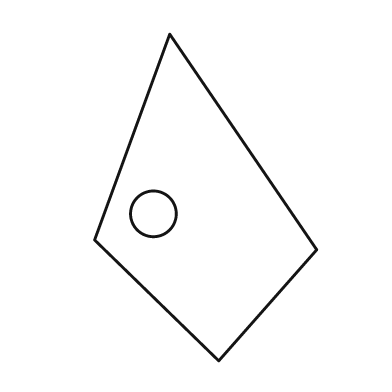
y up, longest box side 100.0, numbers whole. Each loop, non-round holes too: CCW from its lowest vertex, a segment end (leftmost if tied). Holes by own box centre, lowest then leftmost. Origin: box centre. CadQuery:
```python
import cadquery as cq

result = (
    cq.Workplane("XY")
    .moveTo(4.0, -50.0)
    .lineTo(34.0, -16.0)
    .lineTo(-11.0, 50.0)
    .lineTo(-34.0, -13.0)
    .close()
    .moveTo(-16.0, -5.0)
    .circle(7.0)
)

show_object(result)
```